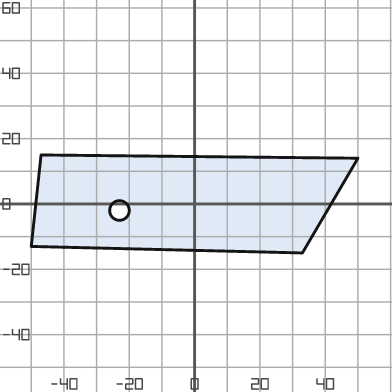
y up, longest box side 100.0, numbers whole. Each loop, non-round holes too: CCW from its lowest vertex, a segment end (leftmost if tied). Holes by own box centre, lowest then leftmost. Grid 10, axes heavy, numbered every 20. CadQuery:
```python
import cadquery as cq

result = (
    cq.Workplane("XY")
    .moveTo(33.0, -15.0)
    .lineTo(50.0, 14.0)
    .lineTo(-47.0, 15.0)
    .lineTo(-50.0, -13.0)
    .close()
    .moveTo(-23.0, -2.0)
    .circle(3.0)
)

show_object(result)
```